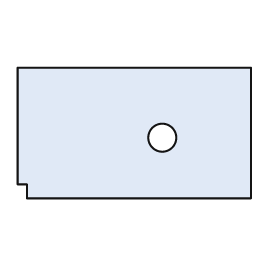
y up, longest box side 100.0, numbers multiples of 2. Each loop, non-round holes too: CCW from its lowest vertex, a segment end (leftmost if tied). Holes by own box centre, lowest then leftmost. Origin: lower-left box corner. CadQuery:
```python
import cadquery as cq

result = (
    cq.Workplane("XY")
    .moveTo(4.0, 0.0)
    .lineTo(100.0, 0.0)
    .lineTo(100.0, 56.0)
    .lineTo(0.0, 56.0)
    .lineTo(0.0, 6.0)
    .lineTo(4.0, 6.0)
    .close()
    .moveTo(62.0, 26.0)
    .circle(6.0)
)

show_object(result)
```